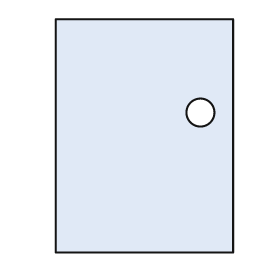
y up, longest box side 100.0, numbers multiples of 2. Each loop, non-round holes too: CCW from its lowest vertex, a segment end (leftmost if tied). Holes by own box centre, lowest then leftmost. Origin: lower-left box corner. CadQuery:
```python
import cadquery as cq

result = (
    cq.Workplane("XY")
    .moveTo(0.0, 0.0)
    .lineTo(76.0, 0.0)
    .lineTo(76.0, 100.0)
    .lineTo(0.0, 100.0)
    .close()
    .moveTo(62.0, 60.0)
    .circle(6.0)
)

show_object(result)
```